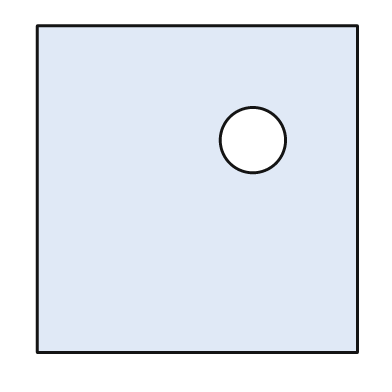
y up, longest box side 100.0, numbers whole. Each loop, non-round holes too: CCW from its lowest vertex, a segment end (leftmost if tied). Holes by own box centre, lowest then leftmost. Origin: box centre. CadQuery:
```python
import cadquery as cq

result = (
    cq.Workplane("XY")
    .moveTo(-49.0, -50.0)
    .lineTo(49.0, -50.0)
    .lineTo(49.0, 50.0)
    .lineTo(-49.0, 50.0)
    .close()
    .moveTo(17.0, 15.0)
    .circle(10.0)
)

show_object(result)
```